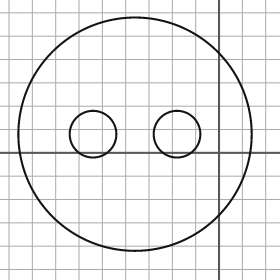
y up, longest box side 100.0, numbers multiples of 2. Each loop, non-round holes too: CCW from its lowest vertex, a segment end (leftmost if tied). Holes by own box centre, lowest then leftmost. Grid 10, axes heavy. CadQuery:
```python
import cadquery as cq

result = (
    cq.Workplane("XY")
    .moveTo(-36.0, 8.0)
    .circle(50.0)
    .moveTo(-54.0, 8.0)
    .circle(10.0)
    .moveTo(-18.0, 8.0)
    .circle(10.0)
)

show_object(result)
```